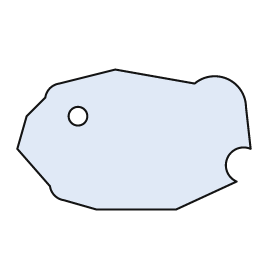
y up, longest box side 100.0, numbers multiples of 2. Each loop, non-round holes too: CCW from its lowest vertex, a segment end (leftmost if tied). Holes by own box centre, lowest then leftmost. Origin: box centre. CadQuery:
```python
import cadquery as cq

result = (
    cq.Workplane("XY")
    .moveTo(-16.0, -30.0)
    .lineTo(18.0, -30.0)
    .lineTo(44.0, -18.0)
    .threePointArc((40.0, -8.0), (50.0, -4.0))
    .lineTo(48.0, 14.0)
    .threePointArc((40.0, 26.0), (26.0, 24.0))
    .lineTo(-8.0, 30.0)
    .lineTo(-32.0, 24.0)
    .threePointArc((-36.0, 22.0), (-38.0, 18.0))
    .lineTo(-46.0, 10.0)
    .lineTo(-50.0, -4.0)
    .lineTo(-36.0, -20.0)
    .threePointArc((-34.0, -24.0), (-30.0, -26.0))
    .close()
    .moveTo(-24.0, 10.0)
    .circle(4.0)
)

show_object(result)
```